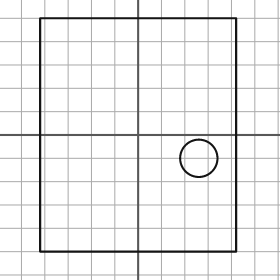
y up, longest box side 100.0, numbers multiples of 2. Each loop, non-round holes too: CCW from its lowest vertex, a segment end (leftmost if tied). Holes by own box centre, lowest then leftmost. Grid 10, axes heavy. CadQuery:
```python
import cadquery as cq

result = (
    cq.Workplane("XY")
    .moveTo(-42.0, -50.0)
    .lineTo(42.0, -50.0)
    .lineTo(42.0, 50.0)
    .lineTo(-42.0, 50.0)
    .close()
    .moveTo(26.0, -10.0)
    .circle(8.0)
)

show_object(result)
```